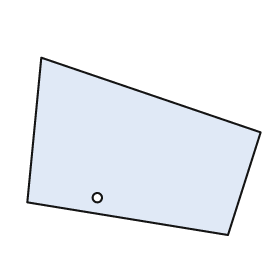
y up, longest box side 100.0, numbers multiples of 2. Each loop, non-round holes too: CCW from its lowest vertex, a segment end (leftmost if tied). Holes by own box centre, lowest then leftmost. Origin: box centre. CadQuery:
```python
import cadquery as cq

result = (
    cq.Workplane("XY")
    .moveTo(36.0, -38.0)
    .lineTo(50.0, 6.0)
    .lineTo(-44.0, 38.0)
    .lineTo(-50.0, -24.0)
    .close()
    .moveTo(-20.0, -22.0)
    .circle(2.0)
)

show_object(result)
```